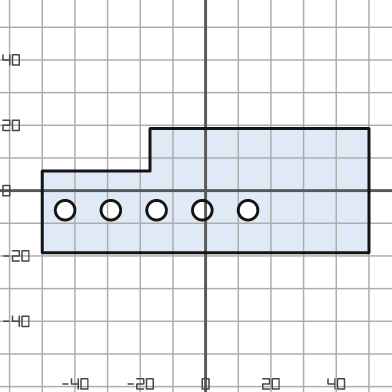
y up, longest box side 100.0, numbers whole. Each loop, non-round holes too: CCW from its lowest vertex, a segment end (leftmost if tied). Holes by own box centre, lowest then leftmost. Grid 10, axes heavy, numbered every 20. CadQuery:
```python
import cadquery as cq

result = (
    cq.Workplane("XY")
    .moveTo(-50.0, -19.0)
    .lineTo(50.0, -19.0)
    .lineTo(50.0, 19.0)
    .lineTo(-17.0, 19.0)
    .lineTo(-17.0, 6.0)
    .lineTo(-50.0, 6.0)
    .close()
    .moveTo(-43.0, -6.0)
    .circle(3.0)
    .moveTo(-29.0, -6.0)
    .circle(3.0)
    .moveTo(-15.0, -6.0)
    .circle(3.0)
    .moveTo(-1.0, -6.0)
    .circle(3.0)
    .moveTo(13.0, -6.0)
    .circle(3.0)
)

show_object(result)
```